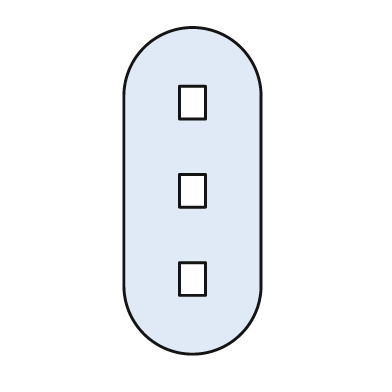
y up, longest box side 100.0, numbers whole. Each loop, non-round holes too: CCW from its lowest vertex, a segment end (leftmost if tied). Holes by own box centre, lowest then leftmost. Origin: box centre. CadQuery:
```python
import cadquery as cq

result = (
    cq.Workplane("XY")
    .moveTo(-21.0, -29.0)
    .threePointArc((0.0, -50.0), (21.0, -29.0))
    .lineTo(21.0, 29.0)
    .threePointArc((0.0, 50.0), (-21.0, 29.0))
    .close()
    .moveTo(-4.0, -32.0)
    .lineTo(4.0, -32.0)
    .lineTo(4.0, -22.0)
    .lineTo(-4.0, -22.0)
    .close()
    .moveTo(-4.0, -5.0)
    .lineTo(4.0, -5.0)
    .lineTo(4.0, 5.0)
    .lineTo(-4.0, 5.0)
    .close()
    .moveTo(-4.0, 22.0)
    .lineTo(4.0, 22.0)
    .lineTo(4.0, 32.0)
    .lineTo(-4.0, 32.0)
    .close()
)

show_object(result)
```